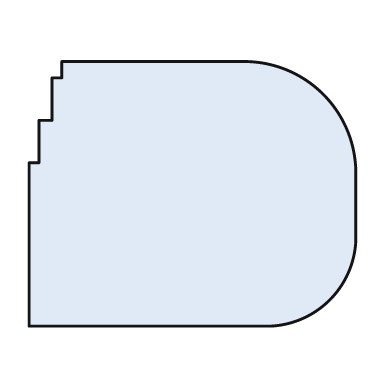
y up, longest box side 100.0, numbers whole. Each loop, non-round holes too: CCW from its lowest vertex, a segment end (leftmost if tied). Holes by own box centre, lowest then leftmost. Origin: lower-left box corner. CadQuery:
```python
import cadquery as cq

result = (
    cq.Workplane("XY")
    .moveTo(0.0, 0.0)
    .lineTo(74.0, 0.0)
    .threePointArc((92.0, 8.0), (100.0, 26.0))
    .lineTo(100.0, 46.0)
    .threePointArc((90.0, 71.0), (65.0, 81.0))
    .lineTo(10.0, 81.0)
    .lineTo(10.0, 76.0)
    .lineTo(7.0, 76.0)
    .lineTo(7.0, 63.0)
    .lineTo(3.0, 63.0)
    .lineTo(3.0, 50.0)
    .lineTo(0.0, 50.0)
    .close()
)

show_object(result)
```